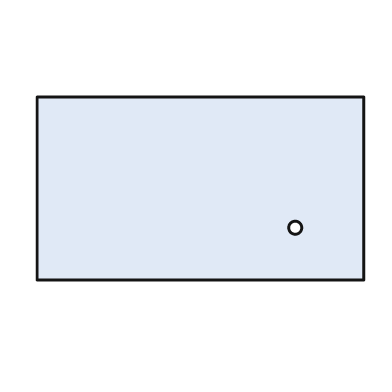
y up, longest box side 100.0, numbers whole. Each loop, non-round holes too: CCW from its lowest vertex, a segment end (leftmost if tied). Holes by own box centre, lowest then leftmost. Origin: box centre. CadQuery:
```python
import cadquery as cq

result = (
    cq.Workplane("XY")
    .moveTo(-50.0, -28.0)
    .lineTo(50.0, -28.0)
    .lineTo(50.0, 28.0)
    .lineTo(-50.0, 28.0)
    .close()
    .moveTo(29.0, -12.0)
    .circle(2.0)
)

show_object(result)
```